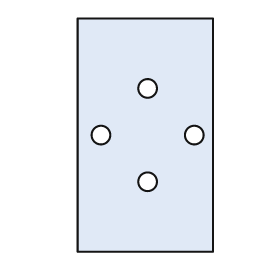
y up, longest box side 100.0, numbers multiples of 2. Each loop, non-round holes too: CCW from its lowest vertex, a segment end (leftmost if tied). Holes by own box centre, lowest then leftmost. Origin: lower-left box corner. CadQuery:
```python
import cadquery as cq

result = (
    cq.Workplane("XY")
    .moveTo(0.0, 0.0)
    .lineTo(58.0, 0.0)
    .lineTo(58.0, 100.0)
    .lineTo(0.0, 100.0)
    .close()
    .moveTo(30.0, 30.0)
    .circle(4.0)
    .moveTo(10.0, 50.0)
    .circle(4.0)
    .moveTo(50.0, 50.0)
    .circle(4.0)
    .moveTo(30.0, 70.0)
    .circle(4.0)
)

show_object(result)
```